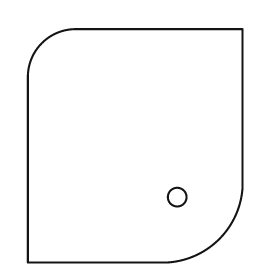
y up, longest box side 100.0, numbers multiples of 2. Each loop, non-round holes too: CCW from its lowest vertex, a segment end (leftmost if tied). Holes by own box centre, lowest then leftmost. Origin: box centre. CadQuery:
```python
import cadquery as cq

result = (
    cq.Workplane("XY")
    .moveTo(-46.0, -50.0)
    .lineTo(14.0, -50.0)
    .threePointArc((36.0, -40.0), (46.0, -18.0))
    .lineTo(46.0, 50.0)
    .lineTo(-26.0, 50.0)
    .threePointArc((-40.0, 44.0), (-46.0, 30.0))
    .close()
    .moveTo(18.0, -22.0)
    .circle(4.0)
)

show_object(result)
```